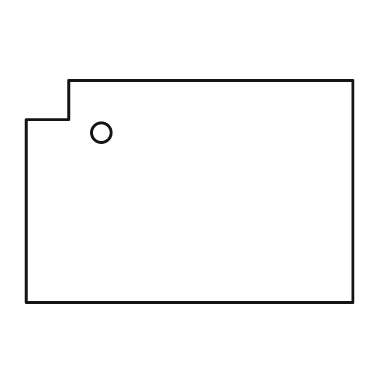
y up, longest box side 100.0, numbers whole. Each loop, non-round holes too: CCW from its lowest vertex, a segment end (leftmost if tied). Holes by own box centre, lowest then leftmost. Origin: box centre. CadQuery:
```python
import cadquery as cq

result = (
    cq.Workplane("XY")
    .moveTo(-50.0, -34.0)
    .lineTo(50.0, -34.0)
    .lineTo(50.0, 34.0)
    .lineTo(-37.0, 34.0)
    .lineTo(-37.0, 22.0)
    .lineTo(-50.0, 22.0)
    .close()
    .moveTo(-27.0, 18.0)
    .circle(3.0)
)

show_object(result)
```